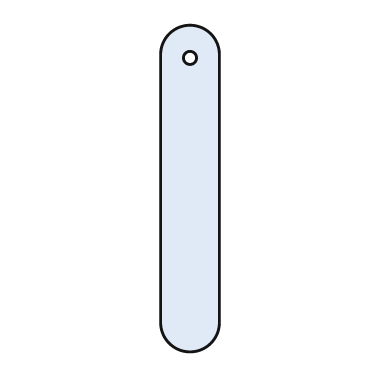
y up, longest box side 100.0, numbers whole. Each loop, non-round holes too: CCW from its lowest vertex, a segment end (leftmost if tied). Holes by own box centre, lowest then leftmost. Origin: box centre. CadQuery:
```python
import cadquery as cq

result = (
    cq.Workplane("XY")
    .moveTo(-9.0, -41.0)
    .threePointArc((0.0, -50.0), (9.0, -41.0))
    .lineTo(9.0, 41.0)
    .threePointArc((0.0, 50.0), (-9.0, 41.0))
    .close()
    .moveTo(0.0, 40.0)
    .circle(2.0)
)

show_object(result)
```